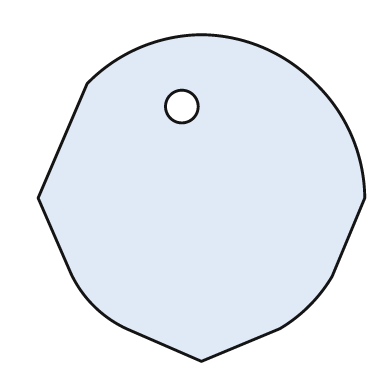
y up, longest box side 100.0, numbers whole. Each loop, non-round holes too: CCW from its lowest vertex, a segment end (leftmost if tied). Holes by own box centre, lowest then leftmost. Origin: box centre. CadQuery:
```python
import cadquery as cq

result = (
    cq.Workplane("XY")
    .moveTo(0.0, -50.0)
    .lineTo(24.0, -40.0)
    .threePointArc((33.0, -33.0), (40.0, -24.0))
    .lineTo(50.0, 0.0)
    .threePointArc((46.0, 19.0), (35.0, 35.0))
    .threePointArc((19.0, 46.0), (0.0, 50.0))
    .threePointArc((-19.0, 46.0), (-35.0, 35.0))
    .lineTo(-50.0, 0.0)
    .lineTo(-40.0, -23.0)
    .threePointArc((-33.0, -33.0), (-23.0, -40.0))
    .close()
    .moveTo(-6.0, 28.0)
    .circle(5.0)
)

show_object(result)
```